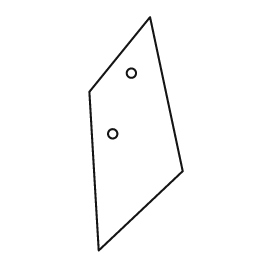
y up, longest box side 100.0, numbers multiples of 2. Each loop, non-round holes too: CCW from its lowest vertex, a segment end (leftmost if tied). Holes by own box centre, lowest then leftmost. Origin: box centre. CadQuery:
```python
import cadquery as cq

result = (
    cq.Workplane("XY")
    .moveTo(-16.0, -50.0)
    .lineTo(20.0, -16.0)
    .lineTo(6.0, 50.0)
    .lineTo(-20.0, 18.0)
    .close()
    .moveTo(-10.0, 0.0)
    .circle(2.0)
    .moveTo(-2.0, 26.0)
    .circle(2.0)
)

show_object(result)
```